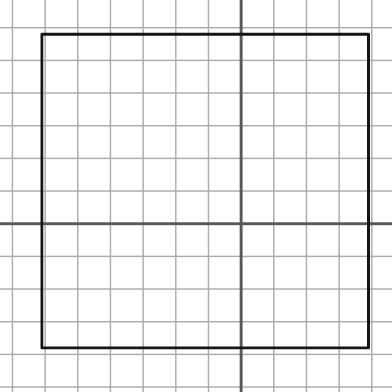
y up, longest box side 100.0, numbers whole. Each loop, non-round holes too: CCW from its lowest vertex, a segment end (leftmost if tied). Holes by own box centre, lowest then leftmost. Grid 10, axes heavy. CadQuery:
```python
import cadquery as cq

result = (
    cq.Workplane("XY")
    .moveTo(-61.0, -38.0)
    .lineTo(39.0, -38.0)
    .lineTo(39.0, 58.0)
    .lineTo(-61.0, 58.0)
    .close()
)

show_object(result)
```